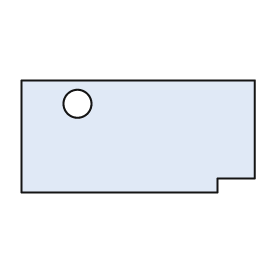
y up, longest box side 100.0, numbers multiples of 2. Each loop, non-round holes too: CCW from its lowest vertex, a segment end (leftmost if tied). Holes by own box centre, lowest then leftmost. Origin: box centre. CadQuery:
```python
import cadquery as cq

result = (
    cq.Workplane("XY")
    .moveTo(-50.0, -24.0)
    .lineTo(34.0, -24.0)
    .lineTo(34.0, -18.0)
    .lineTo(50.0, -18.0)
    .lineTo(50.0, 24.0)
    .lineTo(-50.0, 24.0)
    .close()
    .moveTo(-26.0, 14.0)
    .circle(6.0)
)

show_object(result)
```